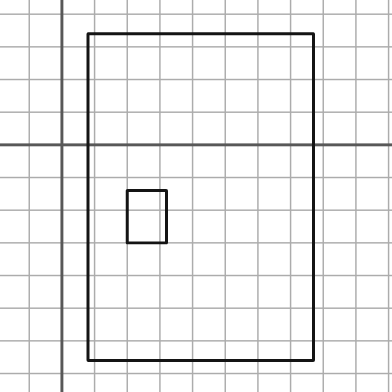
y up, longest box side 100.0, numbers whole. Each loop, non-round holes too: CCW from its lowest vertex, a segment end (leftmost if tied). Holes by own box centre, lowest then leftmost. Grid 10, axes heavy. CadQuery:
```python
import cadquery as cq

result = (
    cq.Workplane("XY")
    .moveTo(8.0, -66.0)
    .lineTo(77.0, -66.0)
    .lineTo(77.0, 34.0)
    .lineTo(8.0, 34.0)
    .close()
    .moveTo(20.0, -30.0)
    .lineTo(32.0, -30.0)
    .lineTo(32.0, -14.0)
    .lineTo(20.0, -14.0)
    .close()
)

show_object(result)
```